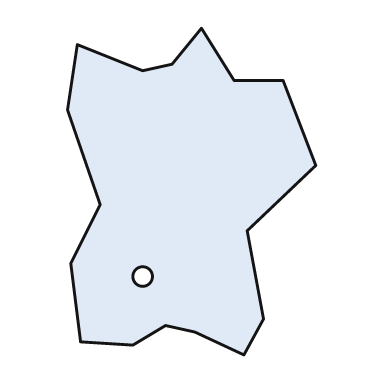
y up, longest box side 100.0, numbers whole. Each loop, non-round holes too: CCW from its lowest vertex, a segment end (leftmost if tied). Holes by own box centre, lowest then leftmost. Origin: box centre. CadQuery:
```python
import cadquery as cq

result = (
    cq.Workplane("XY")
    .moveTo(16.0, -50.0)
    .lineTo(22.0, -39.0)
    .lineTo(17.0, -12.0)
    .lineTo(38.0, 8.0)
    .lineTo(28.0, 34.0)
    .lineTo(13.0, 34.0)
    .lineTo(3.0, 50.0)
    .lineTo(-6.0, 39.0)
    .lineTo(-15.0, 37.0)
    .lineTo(-35.0, 45.0)
    .lineTo(-38.0, 25.0)
    .lineTo(-28.0, -4.0)
    .lineTo(-37.0, -22.0)
    .lineTo(-34.0, -46.0)
    .lineTo(-18.0, -47.0)
    .lineTo(-8.0, -41.0)
    .lineTo(1.0, -43.0)
    .close()
    .moveTo(-15.0, -26.0)
    .circle(3.0)
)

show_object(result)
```